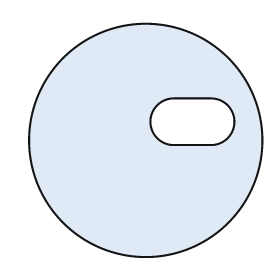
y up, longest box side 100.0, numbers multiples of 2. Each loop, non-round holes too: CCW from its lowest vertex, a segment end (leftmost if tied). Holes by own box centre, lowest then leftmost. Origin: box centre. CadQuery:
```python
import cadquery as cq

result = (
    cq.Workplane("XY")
    .moveTo(0.0, 0.0)
    .circle(50.0)
    .moveTo(12.0, -2.0)
    .lineTo(28.0, -2.0)
    .threePointArc((38.0, 8.0), (28.0, 18.0))
    .lineTo(12.0, 18.0)
    .threePointArc((2.0, 8.0), (12.0, -2.0))
    .close()
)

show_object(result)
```